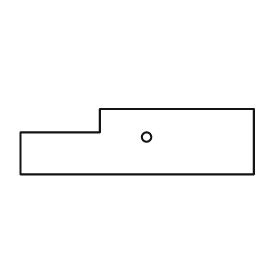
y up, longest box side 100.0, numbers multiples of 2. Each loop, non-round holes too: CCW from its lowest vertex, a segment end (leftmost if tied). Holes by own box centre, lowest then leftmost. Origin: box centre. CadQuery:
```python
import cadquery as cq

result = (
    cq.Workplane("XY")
    .moveTo(-50.0, -14.0)
    .lineTo(50.0, -14.0)
    .lineTo(50.0, 14.0)
    .lineTo(-16.0, 14.0)
    .lineTo(-16.0, 4.0)
    .lineTo(-50.0, 4.0)
    .close()
    .moveTo(4.0, 2.0)
    .circle(2.0)
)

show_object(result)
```